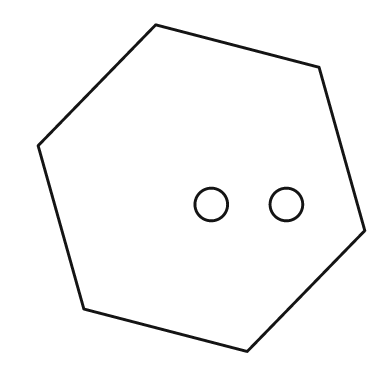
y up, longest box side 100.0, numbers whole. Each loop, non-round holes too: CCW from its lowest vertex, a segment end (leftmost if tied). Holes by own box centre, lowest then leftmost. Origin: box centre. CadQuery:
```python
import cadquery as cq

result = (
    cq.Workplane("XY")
    .moveTo(14.0, -50.0)
    .lineTo(50.0, -13.0)
    .lineTo(36.0, 37.0)
    .lineTo(-14.0, 50.0)
    .lineTo(-50.0, 13.0)
    .lineTo(-36.0, -37.0)
    .close()
    .moveTo(3.0, -5.0)
    .circle(5.0)
    .moveTo(26.0, -5.0)
    .circle(5.0)
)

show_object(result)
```